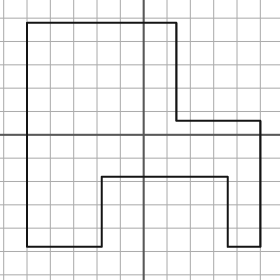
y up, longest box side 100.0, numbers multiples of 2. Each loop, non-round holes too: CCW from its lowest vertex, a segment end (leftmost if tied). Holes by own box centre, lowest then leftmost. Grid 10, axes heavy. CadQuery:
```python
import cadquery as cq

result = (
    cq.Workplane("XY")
    .moveTo(-50.0, -48.0)
    .lineTo(-18.0, -48.0)
    .lineTo(-18.0, -18.0)
    .lineTo(36.0, -18.0)
    .lineTo(36.0, -48.0)
    .lineTo(50.0, -48.0)
    .lineTo(50.0, 6.0)
    .lineTo(14.0, 6.0)
    .lineTo(14.0, 48.0)
    .lineTo(-50.0, 48.0)
    .close()
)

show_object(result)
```